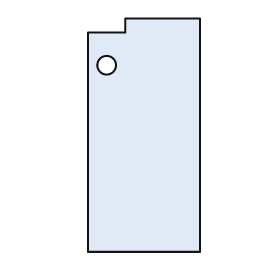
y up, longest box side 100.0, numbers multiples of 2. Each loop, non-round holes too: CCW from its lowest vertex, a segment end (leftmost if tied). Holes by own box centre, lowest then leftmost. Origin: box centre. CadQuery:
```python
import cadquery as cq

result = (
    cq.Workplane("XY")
    .moveTo(-24.0, -50.0)
    .lineTo(24.0, -50.0)
    .lineTo(24.0, 50.0)
    .lineTo(-8.0, 50.0)
    .lineTo(-8.0, 44.0)
    .lineTo(-24.0, 44.0)
    .close()
    .moveTo(-16.0, 30.0)
    .circle(4.0)
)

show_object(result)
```